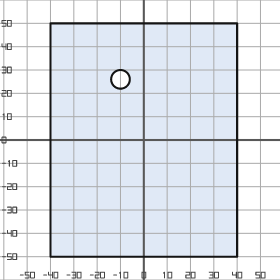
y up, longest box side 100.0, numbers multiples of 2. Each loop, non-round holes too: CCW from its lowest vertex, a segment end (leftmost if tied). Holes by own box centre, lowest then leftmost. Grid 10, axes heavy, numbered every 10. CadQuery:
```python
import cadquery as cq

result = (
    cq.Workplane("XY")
    .moveTo(-40.0, -50.0)
    .lineTo(40.0, -50.0)
    .lineTo(40.0, 50.0)
    .lineTo(-40.0, 50.0)
    .close()
    .moveTo(-10.0, 26.0)
    .circle(4.0)
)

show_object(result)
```